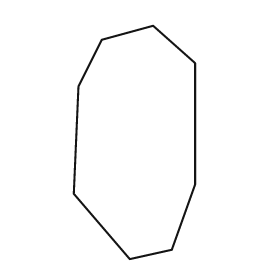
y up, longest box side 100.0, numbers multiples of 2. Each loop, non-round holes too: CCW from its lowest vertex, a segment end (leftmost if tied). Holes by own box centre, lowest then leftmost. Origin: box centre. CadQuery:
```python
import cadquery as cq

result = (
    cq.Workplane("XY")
    .moveTo(-2.0, -50.0)
    .lineTo(16.0, -46.0)
    .lineTo(26.0, -18.0)
    .lineTo(26.0, 34.0)
    .lineTo(8.0, 50.0)
    .lineTo(-14.0, 44.0)
    .lineTo(-24.0, 24.0)
    .lineTo(-26.0, -22.0)
    .close()
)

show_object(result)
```